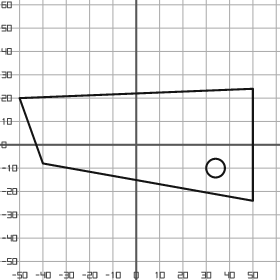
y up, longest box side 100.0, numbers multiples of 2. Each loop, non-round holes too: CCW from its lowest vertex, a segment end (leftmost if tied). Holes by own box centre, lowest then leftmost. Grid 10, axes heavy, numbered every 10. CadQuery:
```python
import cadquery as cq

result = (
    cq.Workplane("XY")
    .moveTo(50.0, -24.0)
    .lineTo(50.0, 24.0)
    .lineTo(-50.0, 20.0)
    .lineTo(-40.0, -8.0)
    .close()
    .moveTo(34.0, -10.0)
    .circle(4.0)
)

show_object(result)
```